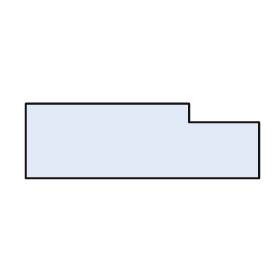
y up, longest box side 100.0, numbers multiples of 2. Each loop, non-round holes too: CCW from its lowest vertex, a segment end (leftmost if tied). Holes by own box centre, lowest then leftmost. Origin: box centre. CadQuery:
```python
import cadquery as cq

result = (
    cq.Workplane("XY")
    .moveTo(-50.0, -16.0)
    .lineTo(50.0, -16.0)
    .lineTo(50.0, 8.0)
    .lineTo(20.0, 8.0)
    .lineTo(20.0, 16.0)
    .lineTo(-50.0, 16.0)
    .close()
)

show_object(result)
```